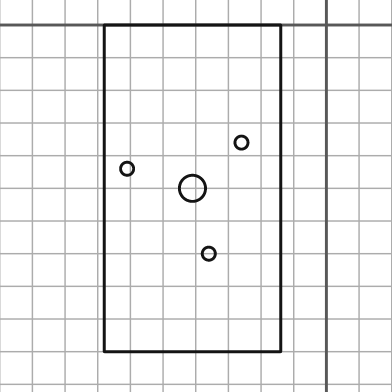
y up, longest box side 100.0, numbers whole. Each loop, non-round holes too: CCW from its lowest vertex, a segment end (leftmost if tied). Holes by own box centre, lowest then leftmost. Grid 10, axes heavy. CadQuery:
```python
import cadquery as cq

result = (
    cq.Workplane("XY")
    .moveTo(-68.0, -100.0)
    .lineTo(-14.0, -100.0)
    .lineTo(-14.0, 0.0)
    .lineTo(-68.0, 0.0)
    .close()
    .moveTo(-36.0, -70.0)
    .circle(2.0)
    .moveTo(-41.0, -50.0)
    .circle(4.0)
    .moveTo(-61.0, -44.0)
    .circle(2.0)
    .moveTo(-26.0, -36.0)
    .circle(2.0)
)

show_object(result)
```